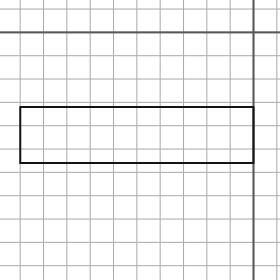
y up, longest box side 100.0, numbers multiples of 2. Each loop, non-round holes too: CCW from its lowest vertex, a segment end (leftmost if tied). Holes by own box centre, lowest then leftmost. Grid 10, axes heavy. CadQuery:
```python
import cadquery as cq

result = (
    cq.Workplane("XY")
    .moveTo(-100.0, -56.0)
    .lineTo(0.0, -56.0)
    .lineTo(0.0, -32.0)
    .lineTo(-100.0, -32.0)
    .close()
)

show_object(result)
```